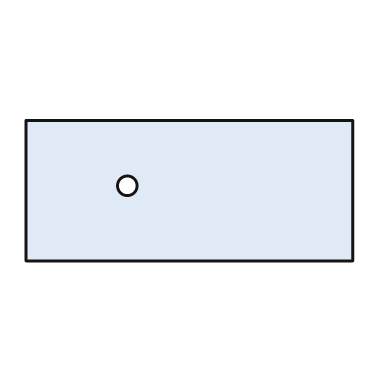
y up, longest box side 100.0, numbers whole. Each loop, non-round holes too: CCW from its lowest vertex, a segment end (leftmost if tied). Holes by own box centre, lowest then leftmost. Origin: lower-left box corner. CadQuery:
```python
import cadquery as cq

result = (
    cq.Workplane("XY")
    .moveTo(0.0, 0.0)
    .lineTo(100.0, 0.0)
    .lineTo(100.0, 43.0)
    .lineTo(0.0, 43.0)
    .close()
    .moveTo(31.0, 23.0)
    .circle(3.0)
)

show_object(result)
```